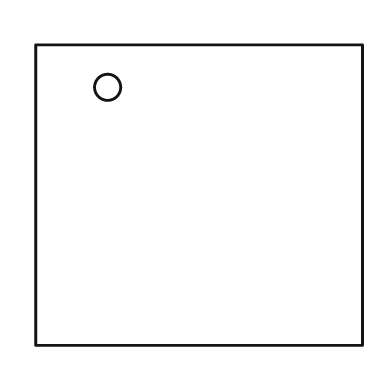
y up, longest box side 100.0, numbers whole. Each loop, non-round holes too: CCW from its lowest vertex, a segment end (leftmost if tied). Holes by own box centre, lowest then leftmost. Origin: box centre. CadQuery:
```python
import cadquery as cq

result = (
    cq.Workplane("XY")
    .moveTo(-50.0, -46.0)
    .lineTo(50.0, -46.0)
    .lineTo(50.0, 46.0)
    .lineTo(-50.0, 46.0)
    .close()
    .moveTo(-28.0, 33.0)
    .circle(4.0)
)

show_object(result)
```